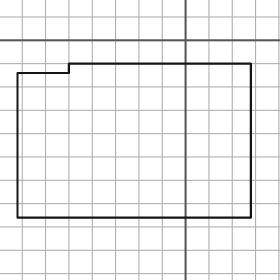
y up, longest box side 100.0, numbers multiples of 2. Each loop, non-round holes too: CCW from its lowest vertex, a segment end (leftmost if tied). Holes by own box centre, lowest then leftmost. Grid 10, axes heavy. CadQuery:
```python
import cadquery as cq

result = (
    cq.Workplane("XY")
    .moveTo(-72.0, -76.0)
    .lineTo(28.0, -76.0)
    .lineTo(28.0, -10.0)
    .lineTo(-50.0, -10.0)
    .lineTo(-50.0, -14.0)
    .lineTo(-72.0, -14.0)
    .close()
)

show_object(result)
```